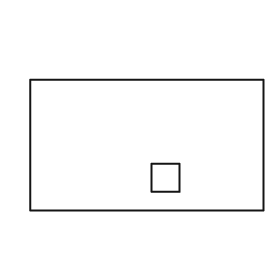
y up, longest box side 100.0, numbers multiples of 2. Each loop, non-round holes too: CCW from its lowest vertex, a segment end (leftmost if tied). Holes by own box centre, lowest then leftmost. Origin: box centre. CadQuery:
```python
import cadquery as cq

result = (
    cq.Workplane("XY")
    .moveTo(-50.0, -28.0)
    .lineTo(50.0, -28.0)
    .lineTo(50.0, 28.0)
    .lineTo(-50.0, 28.0)
    .close()
    .moveTo(2.0, -20.0)
    .lineTo(14.0, -20.0)
    .lineTo(14.0, -8.0)
    .lineTo(2.0, -8.0)
    .close()
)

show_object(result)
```